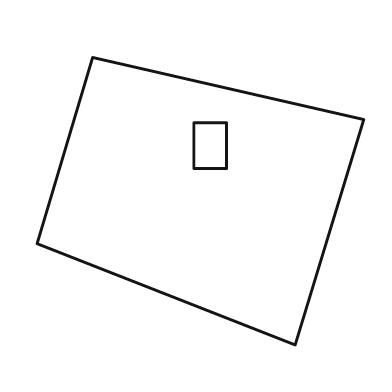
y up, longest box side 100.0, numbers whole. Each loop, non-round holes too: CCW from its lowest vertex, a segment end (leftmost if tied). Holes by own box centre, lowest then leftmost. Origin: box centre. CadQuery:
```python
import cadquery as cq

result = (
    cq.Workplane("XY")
    .moveTo(29.0, -44.0)
    .lineTo(50.0, 25.0)
    .lineTo(-33.0, 44.0)
    .lineTo(-50.0, -13.0)
    .close()
    .moveTo(-2.0, 10.0)
    .lineTo(8.0, 10.0)
    .lineTo(8.0, 24.0)
    .lineTo(-2.0, 24.0)
    .close()
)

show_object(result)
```